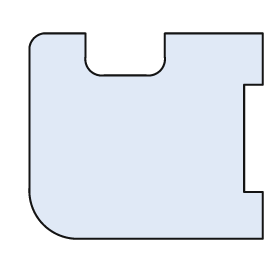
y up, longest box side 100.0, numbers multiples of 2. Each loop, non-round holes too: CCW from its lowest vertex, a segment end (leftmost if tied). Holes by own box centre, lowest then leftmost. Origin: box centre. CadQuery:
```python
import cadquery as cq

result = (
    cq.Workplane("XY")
    .moveTo(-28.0, -44.0)
    .lineTo(50.0, -44.0)
    .lineTo(50.0, -24.0)
    .lineTo(42.0, -24.0)
    .lineTo(42.0, 22.0)
    .lineTo(50.0, 22.0)
    .lineTo(50.0, 44.0)
    .lineTo(8.0, 44.0)
    .lineTo(8.0, 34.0)
    .threePointArc((6.0, 28.0), (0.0, 26.0))
    .lineTo(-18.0, 26.0)
    .threePointArc((-24.0, 28.0), (-26.0, 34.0))
    .lineTo(-26.0, 44.0)
    .lineTo(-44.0, 44.0)
    .threePointArc((-48.0, 42.0), (-50.0, 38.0))
    .lineTo(-50.0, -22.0)
    .threePointArc((-44.0, -38.0), (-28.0, -44.0))
    .close()
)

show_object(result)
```